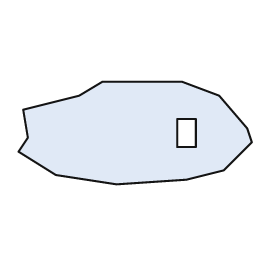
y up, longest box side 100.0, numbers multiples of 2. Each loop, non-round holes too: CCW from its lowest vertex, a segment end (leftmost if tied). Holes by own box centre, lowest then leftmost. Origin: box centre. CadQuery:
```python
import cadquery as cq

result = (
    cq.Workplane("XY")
    .moveTo(-8.0, -22.0)
    .lineTo(22.0, -20.0)
    .lineTo(38.0, -16.0)
    .lineTo(50.0, -4.0)
    .lineTo(48.0, 2.0)
    .lineTo(36.0, 16.0)
    .lineTo(20.0, 22.0)
    .lineTo(-14.0, 22.0)
    .lineTo(-24.0, 16.0)
    .lineTo(-48.0, 10.0)
    .lineTo(-46.0, -2.0)
    .lineTo(-50.0, -8.0)
    .lineTo(-34.0, -18.0)
    .close()
    .moveTo(18.0, -6.0)
    .lineTo(26.0, -6.0)
    .lineTo(26.0, 6.0)
    .lineTo(18.0, 6.0)
    .close()
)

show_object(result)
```